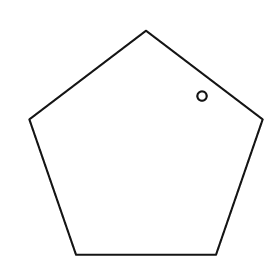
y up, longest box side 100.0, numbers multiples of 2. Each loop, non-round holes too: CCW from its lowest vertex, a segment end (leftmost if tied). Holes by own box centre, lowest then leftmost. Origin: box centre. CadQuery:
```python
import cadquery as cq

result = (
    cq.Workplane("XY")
    .moveTo(-30.0, -48.0)
    .lineTo(30.0, -48.0)
    .lineTo(50.0, 10.0)
    .lineTo(0.0, 48.0)
    .lineTo(-50.0, 10.0)
    .close()
    .moveTo(24.0, 20.0)
    .circle(2.0)
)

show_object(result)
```